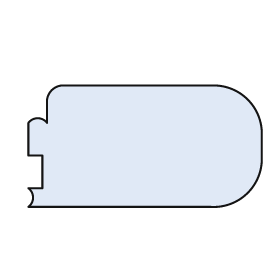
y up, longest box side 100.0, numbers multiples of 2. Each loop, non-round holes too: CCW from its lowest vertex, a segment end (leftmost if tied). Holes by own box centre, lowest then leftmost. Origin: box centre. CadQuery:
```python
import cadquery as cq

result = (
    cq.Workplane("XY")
    .moveTo(-50.0, -26.0)
    .lineTo(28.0, -26.0)
    .threePointArc((44.0, -20.0), (50.0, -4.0))
    .lineTo(50.0, 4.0)
    .threePointArc((44.0, 20.0), (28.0, 26.0))
    .lineTo(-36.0, 26.0)
    .threePointArc((-40.0, 24.0), (-42.0, 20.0))
    .lineTo(-42.0, 10.0)
    .threePointArc((-46.0, 12.0), (-50.0, 10.0))
    .lineTo(-50.0, -4.0)
    .lineTo(-44.0, -4.0)
    .lineTo(-44.0, -18.0)
    .lineTo(-50.0, -18.0)
    .threePointArc((-48.0, -22.0), (-50.0, -26.0))
    .close()
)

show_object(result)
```